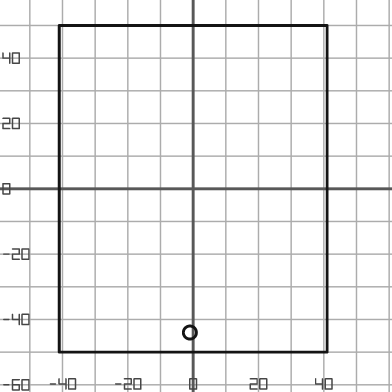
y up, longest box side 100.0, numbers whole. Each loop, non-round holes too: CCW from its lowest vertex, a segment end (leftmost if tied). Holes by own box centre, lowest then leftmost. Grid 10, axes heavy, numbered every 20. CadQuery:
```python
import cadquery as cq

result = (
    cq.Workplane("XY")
    .moveTo(-41.0, -50.0)
    .lineTo(41.0, -50.0)
    .lineTo(41.0, 50.0)
    .lineTo(-41.0, 50.0)
    .close()
    .moveTo(-1.0, -44.0)
    .circle(2.0)
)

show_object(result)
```